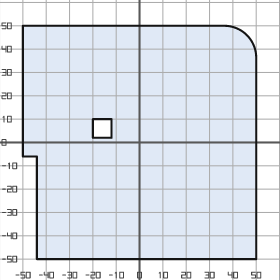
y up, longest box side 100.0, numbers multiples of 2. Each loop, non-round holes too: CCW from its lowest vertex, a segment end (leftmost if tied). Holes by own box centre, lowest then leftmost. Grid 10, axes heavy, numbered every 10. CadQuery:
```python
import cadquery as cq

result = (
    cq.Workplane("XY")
    .moveTo(-44.0, -50.0)
    .lineTo(50.0, -50.0)
    .lineTo(50.0, 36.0)
    .threePointArc((46.0, 46.0), (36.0, 50.0))
    .lineTo(-50.0, 50.0)
    .lineTo(-50.0, -6.0)
    .lineTo(-44.0, -6.0)
    .close()
    .moveTo(-20.0, 2.0)
    .lineTo(-12.0, 2.0)
    .lineTo(-12.0, 10.0)
    .lineTo(-20.0, 10.0)
    .close()
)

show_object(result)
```